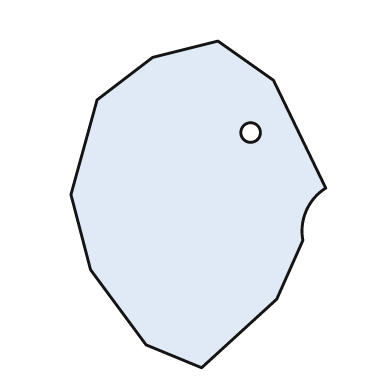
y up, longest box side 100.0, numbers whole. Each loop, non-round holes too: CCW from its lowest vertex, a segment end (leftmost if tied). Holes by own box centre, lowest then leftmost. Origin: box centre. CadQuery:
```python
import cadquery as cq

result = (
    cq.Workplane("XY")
    .moveTo(1.0, -50.0)
    .lineTo(24.0, -29.0)
    .lineTo(32.0, -11.0)
    .threePointArc((33.0, -2.0), (39.0, 5.0))
    .lineTo(23.0, 38.0)
    .lineTo(6.0, 50.0)
    .lineTo(-14.0, 45.0)
    .lineTo(-31.0, 32.0)
    .lineTo(-39.0, 3.0)
    .lineTo(-33.0, -20.0)
    .lineTo(-16.0, -43.0)
    .close()
    .moveTo(16.0, 22.0)
    .circle(3.0)
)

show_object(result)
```